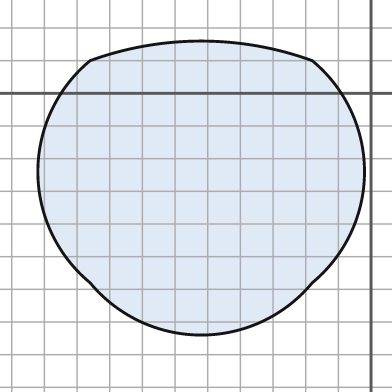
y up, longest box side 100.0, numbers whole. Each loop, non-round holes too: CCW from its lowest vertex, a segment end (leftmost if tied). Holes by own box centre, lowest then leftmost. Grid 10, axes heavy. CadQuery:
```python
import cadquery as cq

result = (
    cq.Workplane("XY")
    .moveTo(-86.0, -58.0)
    .threePointArc((-52.0, -74.0), (-18.0, -58.0))
    .threePointArc((-2.0, -24.0), (-18.0, 10.0))
    .threePointArc((-52.0, 16.0), (-86.0, 10.0))
    .threePointArc((-102.0, -24.0), (-86.0, -58.0))
    .close()
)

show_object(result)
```